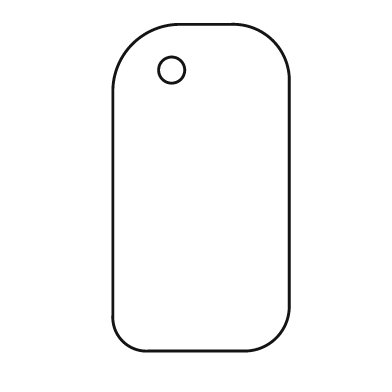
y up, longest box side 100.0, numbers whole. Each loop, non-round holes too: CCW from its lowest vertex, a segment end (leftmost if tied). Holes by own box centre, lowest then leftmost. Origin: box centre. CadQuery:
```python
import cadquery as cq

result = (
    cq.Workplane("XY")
    .moveTo(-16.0, -50.0)
    .lineTo(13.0, -50.0)
    .threePointArc((23.0, -46.0), (27.0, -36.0))
    .lineTo(27.0, 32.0)
    .threePointArc((22.0, 45.0), (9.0, 50.0))
    .lineTo(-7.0, 50.0)
    .threePointArc((-21.0, 44.0), (-27.0, 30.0))
    .lineTo(-27.0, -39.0)
    .threePointArc((-24.0, -47.0), (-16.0, -50.0))
    .close()
    .moveTo(-9.0, 36.0)
    .circle(4.0)
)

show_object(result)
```